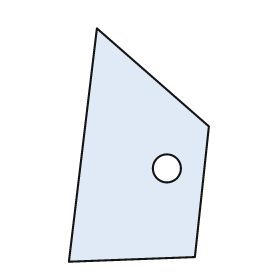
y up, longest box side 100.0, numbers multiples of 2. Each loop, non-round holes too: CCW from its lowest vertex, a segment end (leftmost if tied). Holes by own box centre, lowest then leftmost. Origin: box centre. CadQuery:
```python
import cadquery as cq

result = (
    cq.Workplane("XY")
    .moveTo(-30.0, -50.0)
    .lineTo(24.0, -48.0)
    .lineTo(30.0, 8.0)
    .lineTo(-18.0, 50.0)
    .close()
    .moveTo(12.0, -10.0)
    .circle(6.0)
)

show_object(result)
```